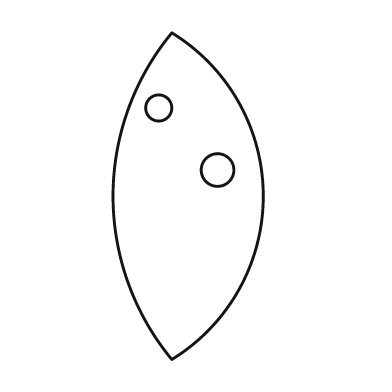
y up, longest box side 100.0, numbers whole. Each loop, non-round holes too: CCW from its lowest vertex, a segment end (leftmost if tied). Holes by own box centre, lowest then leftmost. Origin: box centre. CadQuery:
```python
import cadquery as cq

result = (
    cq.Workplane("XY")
    .moveTo(-5.0, -50.0)
    .threePointArc((23.0, 0.0), (-5.0, 50.0))
    .threePointArc((-23.0, 0.0), (-5.0, -50.0))
    .close()
    .moveTo(9.0, 8.0)
    .circle(5.0)
    .moveTo(-9.0, 27.0)
    .circle(4.0)
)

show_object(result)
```